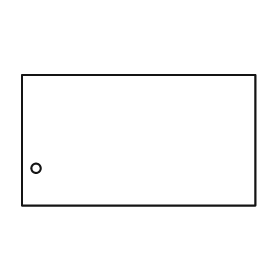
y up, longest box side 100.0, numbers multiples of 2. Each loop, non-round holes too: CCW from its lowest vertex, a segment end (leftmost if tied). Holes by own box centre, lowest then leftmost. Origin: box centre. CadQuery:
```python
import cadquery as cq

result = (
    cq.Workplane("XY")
    .moveTo(-50.0, -28.0)
    .lineTo(50.0, -28.0)
    .lineTo(50.0, 28.0)
    .lineTo(-50.0, 28.0)
    .close()
    .moveTo(-44.0, -12.0)
    .circle(2.0)
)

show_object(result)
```